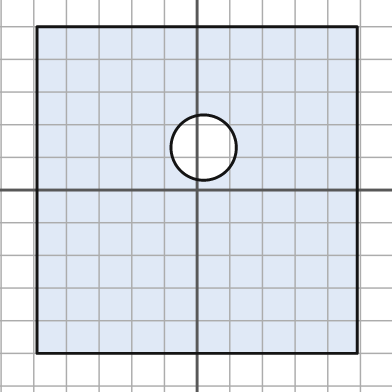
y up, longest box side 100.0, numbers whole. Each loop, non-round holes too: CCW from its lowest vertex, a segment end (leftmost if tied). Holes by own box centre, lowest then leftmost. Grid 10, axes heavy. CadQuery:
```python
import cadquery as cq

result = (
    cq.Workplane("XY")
    .moveTo(-49.0, -50.0)
    .lineTo(49.0, -50.0)
    .lineTo(49.0, 50.0)
    .lineTo(-49.0, 50.0)
    .close()
    .moveTo(2.0, 13.0)
    .circle(10.0)
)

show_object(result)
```